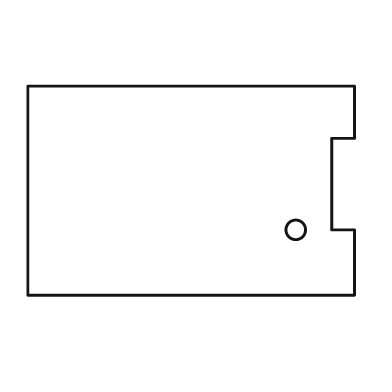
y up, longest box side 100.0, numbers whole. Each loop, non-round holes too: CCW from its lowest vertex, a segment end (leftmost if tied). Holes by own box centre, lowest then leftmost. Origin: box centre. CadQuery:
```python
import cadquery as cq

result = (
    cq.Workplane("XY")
    .moveTo(-50.0, -32.0)
    .lineTo(50.0, -32.0)
    .lineTo(50.0, -12.0)
    .lineTo(43.0, -12.0)
    .lineTo(43.0, 16.0)
    .lineTo(50.0, 16.0)
    .lineTo(50.0, 32.0)
    .lineTo(-50.0, 32.0)
    .close()
    .moveTo(32.0, -12.0)
    .circle(3.0)
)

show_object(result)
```